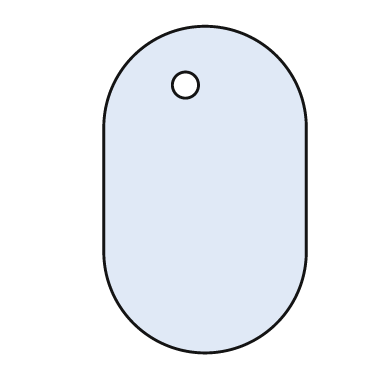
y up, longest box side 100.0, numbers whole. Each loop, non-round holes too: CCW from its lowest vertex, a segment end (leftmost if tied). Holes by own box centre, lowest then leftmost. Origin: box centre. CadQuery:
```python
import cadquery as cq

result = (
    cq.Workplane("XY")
    .moveTo(-31.0, -19.0)
    .threePointArc((0.0, -50.0), (31.0, -19.0))
    .lineTo(31.0, 19.0)
    .threePointArc((0.0, 50.0), (-31.0, 19.0))
    .close()
    .moveTo(-6.0, 32.0)
    .circle(4.0)
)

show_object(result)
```